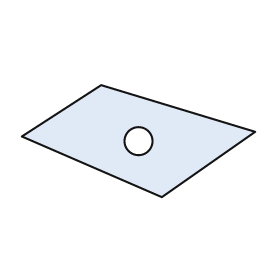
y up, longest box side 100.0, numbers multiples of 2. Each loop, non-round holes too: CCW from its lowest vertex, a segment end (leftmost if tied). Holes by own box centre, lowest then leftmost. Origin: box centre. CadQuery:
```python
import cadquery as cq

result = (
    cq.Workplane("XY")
    .moveTo(10.0, -24.0)
    .lineTo(50.0, 4.0)
    .lineTo(-16.0, 24.0)
    .lineTo(-50.0, 2.0)
    .close()
    .moveTo(0.0, 0.0)
    .circle(6.0)
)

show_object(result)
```